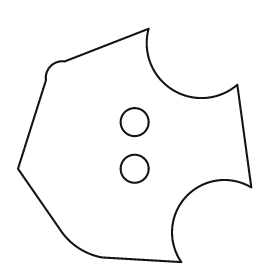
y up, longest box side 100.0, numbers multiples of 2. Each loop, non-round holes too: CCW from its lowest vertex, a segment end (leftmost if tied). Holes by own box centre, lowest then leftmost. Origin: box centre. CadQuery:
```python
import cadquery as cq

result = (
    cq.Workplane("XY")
    .moveTo(20.0, -50.0)
    .threePointArc((22.0, -22.0), (50.0, -18.0))
    .lineTo(44.0, 26.0)
    .threePointArc((16.0, 24.0), (6.0, 50.0))
    .lineTo(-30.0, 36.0)
    .threePointArc((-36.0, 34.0), (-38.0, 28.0))
    .lineTo(-50.0, -10.0)
    .lineTo(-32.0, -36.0)
    .threePointArc((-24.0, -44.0), (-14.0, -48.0))
    .close()
    .moveTo(0.0, -10.0)
    .circle(6.0)
    .moveTo(0.0, 10.0)
    .circle(6.0)
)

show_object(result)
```